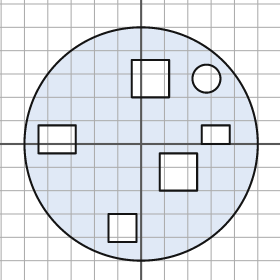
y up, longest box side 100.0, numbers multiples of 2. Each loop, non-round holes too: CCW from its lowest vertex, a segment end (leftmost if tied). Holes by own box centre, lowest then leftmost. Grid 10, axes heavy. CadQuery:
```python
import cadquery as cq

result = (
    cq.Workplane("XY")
    .moveTo(0.0, 0.0)
    .circle(50.0)
    .moveTo(-14.0, -42.0)
    .lineTo(-2.0, -42.0)
    .lineTo(-2.0, -30.0)
    .lineTo(-14.0, -30.0)
    .close()
    .moveTo(8.0, -20.0)
    .lineTo(24.0, -20.0)
    .lineTo(24.0, -4.0)
    .lineTo(8.0, -4.0)
    .close()
    .moveTo(-44.0, -4.0)
    .lineTo(-28.0, -4.0)
    .lineTo(-28.0, 8.0)
    .lineTo(-44.0, 8.0)
    .close()
    .moveTo(26.0, 0.0)
    .lineTo(38.0, 0.0)
    .lineTo(38.0, 8.0)
    .lineTo(26.0, 8.0)
    .close()
    .moveTo(-4.0, 20.0)
    .lineTo(12.0, 20.0)
    .lineTo(12.0, 36.0)
    .lineTo(-4.0, 36.0)
    .close()
    .moveTo(28.0, 28.0)
    .circle(6.0)
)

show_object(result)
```